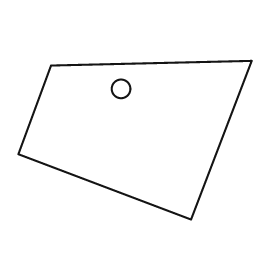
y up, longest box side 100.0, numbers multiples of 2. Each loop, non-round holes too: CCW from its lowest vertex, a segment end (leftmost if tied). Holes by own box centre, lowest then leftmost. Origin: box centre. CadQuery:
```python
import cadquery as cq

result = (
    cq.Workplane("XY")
    .moveTo(24.0, -34.0)
    .lineTo(50.0, 34.0)
    .lineTo(-36.0, 32.0)
    .lineTo(-50.0, -6.0)
    .close()
    .moveTo(-6.0, 22.0)
    .circle(4.0)
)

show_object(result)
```